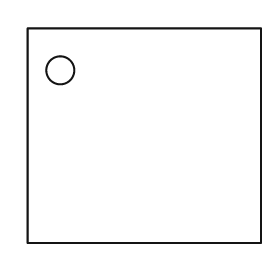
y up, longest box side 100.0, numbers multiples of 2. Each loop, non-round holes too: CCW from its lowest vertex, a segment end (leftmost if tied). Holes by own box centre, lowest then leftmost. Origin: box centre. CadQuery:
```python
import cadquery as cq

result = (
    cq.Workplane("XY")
    .moveTo(-50.0, -46.0)
    .lineTo(50.0, -46.0)
    .lineTo(50.0, 46.0)
    .lineTo(-50.0, 46.0)
    .close()
    .moveTo(-36.0, 28.0)
    .circle(6.0)
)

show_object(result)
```